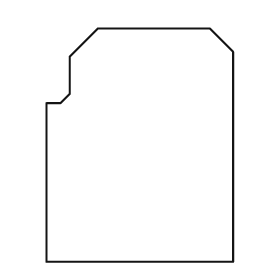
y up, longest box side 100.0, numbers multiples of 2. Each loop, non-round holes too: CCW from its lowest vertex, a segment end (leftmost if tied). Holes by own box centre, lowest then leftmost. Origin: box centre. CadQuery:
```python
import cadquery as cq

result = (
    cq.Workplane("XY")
    .moveTo(-40.0, -50.0)
    .lineTo(40.0, -50.0)
    .lineTo(40.0, 40.0)
    .lineTo(30.0, 50.0)
    .lineTo(-18.0, 50.0)
    .lineTo(-30.0, 38.0)
    .lineTo(-30.0, 22.0)
    .lineTo(-34.0, 18.0)
    .lineTo(-40.0, 18.0)
    .close()
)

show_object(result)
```